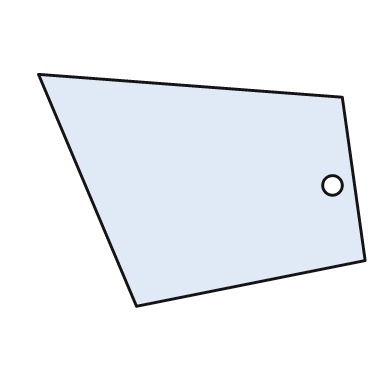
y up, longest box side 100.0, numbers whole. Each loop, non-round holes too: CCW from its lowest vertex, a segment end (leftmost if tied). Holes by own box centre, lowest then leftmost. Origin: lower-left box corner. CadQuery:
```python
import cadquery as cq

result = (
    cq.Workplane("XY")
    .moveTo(30.0, 0.0)
    .lineTo(100.0, 14.0)
    .lineTo(93.0, 64.0)
    .lineTo(0.0, 71.0)
    .close()
    .moveTo(90.0, 37.0)
    .circle(3.0)
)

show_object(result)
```